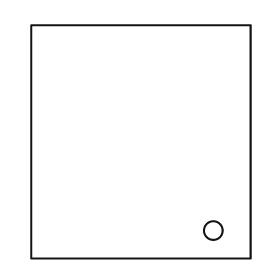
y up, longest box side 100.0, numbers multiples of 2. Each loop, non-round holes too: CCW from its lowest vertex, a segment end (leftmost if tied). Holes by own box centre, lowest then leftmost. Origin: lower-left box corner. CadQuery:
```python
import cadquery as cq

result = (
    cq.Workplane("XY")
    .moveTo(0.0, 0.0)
    .lineTo(94.0, 0.0)
    .lineTo(94.0, 100.0)
    .lineTo(0.0, 100.0)
    .close()
    .moveTo(78.0, 12.0)
    .circle(4.0)
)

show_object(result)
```